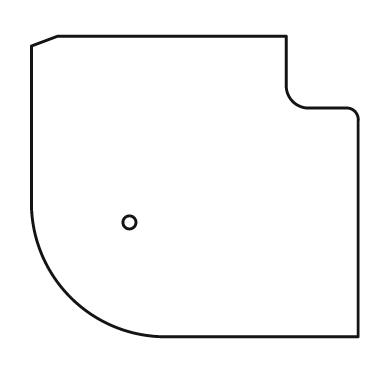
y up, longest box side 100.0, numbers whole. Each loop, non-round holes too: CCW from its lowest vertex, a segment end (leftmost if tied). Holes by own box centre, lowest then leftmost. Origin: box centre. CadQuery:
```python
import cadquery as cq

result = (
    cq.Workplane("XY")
    .moveTo(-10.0, -46.0)
    .lineTo(50.0, -46.0)
    .lineTo(50.0, 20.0)
    .threePointArc((49.0, 23.0), (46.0, 24.0))
    .lineTo(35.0, 24.0)
    .threePointArc((30.0, 26.0), (28.0, 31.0))
    .lineTo(28.0, 46.0)
    .lineTo(-42.0, 46.0)
    .lineTo(-50.0, 43.0)
    .lineTo(-50.0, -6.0)
    .threePointArc((-38.0, -34.0), (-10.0, -46.0))
    .close()
    .moveTo(-20.0, -11.0)
    .circle(2.0)
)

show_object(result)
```